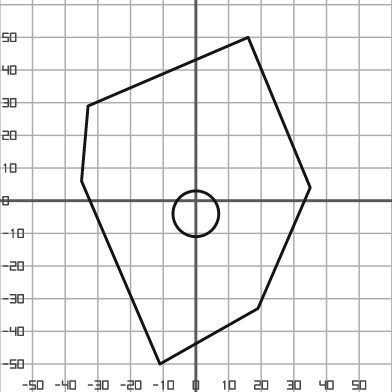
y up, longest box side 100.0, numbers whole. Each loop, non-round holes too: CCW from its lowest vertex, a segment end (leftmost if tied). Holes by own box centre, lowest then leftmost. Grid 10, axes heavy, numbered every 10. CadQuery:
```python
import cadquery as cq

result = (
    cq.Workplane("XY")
    .moveTo(-11.0, -50.0)
    .lineTo(19.0, -33.0)
    .lineTo(35.0, 4.0)
    .lineTo(16.0, 50.0)
    .lineTo(-33.0, 29.0)
    .lineTo(-35.0, 6.0)
    .close()
    .moveTo(0.0, -4.0)
    .circle(7.0)
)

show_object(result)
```